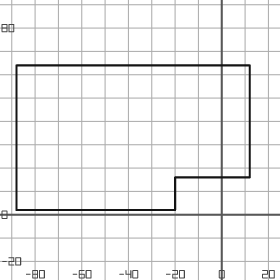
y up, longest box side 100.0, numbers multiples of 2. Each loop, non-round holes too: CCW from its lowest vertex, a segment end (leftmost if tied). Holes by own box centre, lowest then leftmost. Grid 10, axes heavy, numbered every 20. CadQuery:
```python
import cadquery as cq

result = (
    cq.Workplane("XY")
    .moveTo(-88.0, 2.0)
    .lineTo(-20.0, 2.0)
    .lineTo(-20.0, 16.0)
    .lineTo(12.0, 16.0)
    .lineTo(12.0, 64.0)
    .lineTo(-88.0, 64.0)
    .close()
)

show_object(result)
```